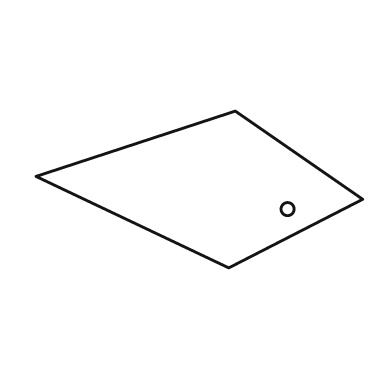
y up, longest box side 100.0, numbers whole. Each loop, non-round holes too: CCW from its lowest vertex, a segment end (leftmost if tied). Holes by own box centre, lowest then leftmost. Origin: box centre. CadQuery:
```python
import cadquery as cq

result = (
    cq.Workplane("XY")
    .moveTo(9.0, -24.0)
    .lineTo(50.0, -3.0)
    .lineTo(11.0, 24.0)
    .lineTo(-50.0, 4.0)
    .close()
    .moveTo(27.0, -6.0)
    .circle(2.0)
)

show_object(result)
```